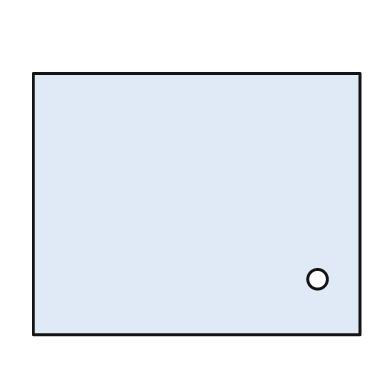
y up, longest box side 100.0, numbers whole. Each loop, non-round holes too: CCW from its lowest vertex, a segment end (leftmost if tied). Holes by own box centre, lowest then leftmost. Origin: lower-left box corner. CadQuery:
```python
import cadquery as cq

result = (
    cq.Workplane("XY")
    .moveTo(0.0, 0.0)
    .lineTo(100.0, 0.0)
    .lineTo(100.0, 80.0)
    .lineTo(0.0, 80.0)
    .close()
    .moveTo(87.0, 17.0)
    .circle(3.0)
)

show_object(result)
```